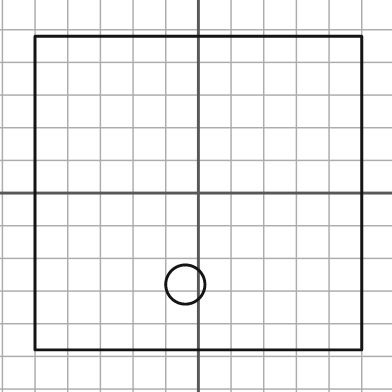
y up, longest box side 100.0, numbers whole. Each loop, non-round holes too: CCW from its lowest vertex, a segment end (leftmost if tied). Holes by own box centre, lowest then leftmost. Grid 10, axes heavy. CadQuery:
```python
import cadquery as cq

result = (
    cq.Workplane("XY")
    .moveTo(-50.0, -48.0)
    .lineTo(50.0, -48.0)
    .lineTo(50.0, 48.0)
    .lineTo(-50.0, 48.0)
    .close()
    .moveTo(-4.0, -28.0)
    .circle(6.0)
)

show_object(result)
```